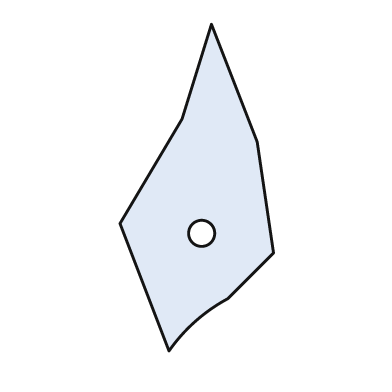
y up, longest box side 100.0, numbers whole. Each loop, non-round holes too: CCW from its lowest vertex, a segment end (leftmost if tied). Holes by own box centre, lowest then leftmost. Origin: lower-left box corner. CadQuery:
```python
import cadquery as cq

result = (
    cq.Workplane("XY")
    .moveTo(15.0, 0.0)
    .threePointArc((23.0, 9.0), (33.0, 16.0))
    .lineTo(47.0, 30.0)
    .lineTo(42.0, 64.0)
    .lineTo(28.0, 100.0)
    .lineTo(19.0, 71.0)
    .lineTo(0.0, 39.0)
    .close()
    .moveTo(25.0, 36.0)
    .circle(4.0)
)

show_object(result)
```